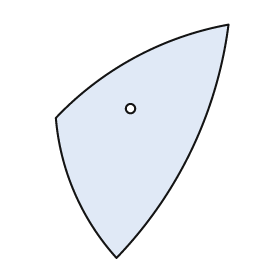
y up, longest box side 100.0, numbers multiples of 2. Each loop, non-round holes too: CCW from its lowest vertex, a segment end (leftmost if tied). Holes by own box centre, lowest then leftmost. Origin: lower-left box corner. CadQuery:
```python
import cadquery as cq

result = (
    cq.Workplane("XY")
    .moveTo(26.0, 0.0)
    .threePointArc((58.0, 46.0), (74.0, 100.0))
    .threePointArc((34.0, 86.0), (0.0, 60.0))
    .threePointArc((8.0, 28.0), (26.0, 0.0))
    .close()
    .moveTo(32.0, 64.0)
    .circle(2.0)
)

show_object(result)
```